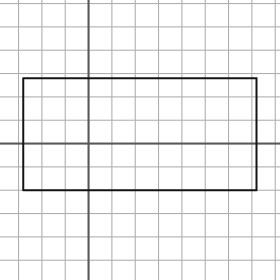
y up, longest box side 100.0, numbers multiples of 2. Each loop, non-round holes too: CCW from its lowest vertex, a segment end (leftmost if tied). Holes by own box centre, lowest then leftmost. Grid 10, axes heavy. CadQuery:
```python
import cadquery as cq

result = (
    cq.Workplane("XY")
    .moveTo(-28.0, -20.0)
    .lineTo(72.0, -20.0)
    .lineTo(72.0, 28.0)
    .lineTo(-28.0, 28.0)
    .close()
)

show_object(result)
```